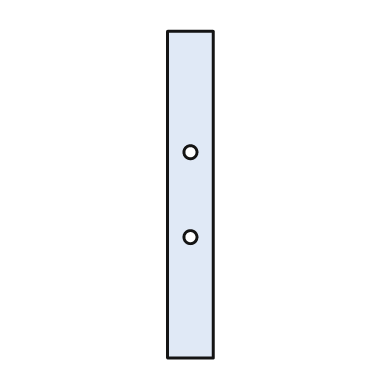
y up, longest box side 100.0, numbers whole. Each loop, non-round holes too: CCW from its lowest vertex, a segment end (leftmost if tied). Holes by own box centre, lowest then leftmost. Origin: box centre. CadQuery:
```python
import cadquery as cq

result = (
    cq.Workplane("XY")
    .moveTo(-7.0, -50.0)
    .lineTo(7.0, -50.0)
    .lineTo(7.0, 50.0)
    .lineTo(-7.0, 50.0)
    .close()
    .moveTo(0.0, -13.0)
    .circle(2.0)
    .moveTo(0.0, 13.0)
    .circle(2.0)
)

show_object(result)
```